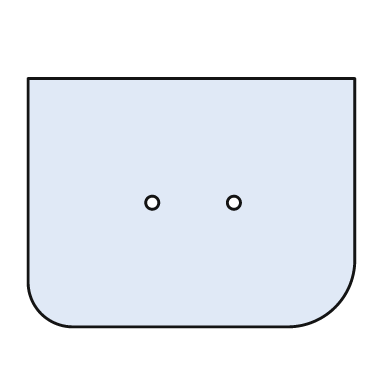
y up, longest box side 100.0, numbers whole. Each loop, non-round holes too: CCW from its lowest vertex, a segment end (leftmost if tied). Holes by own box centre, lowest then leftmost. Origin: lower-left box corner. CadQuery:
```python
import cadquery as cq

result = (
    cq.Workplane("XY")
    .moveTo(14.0, 0.0)
    .lineTo(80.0, 0.0)
    .threePointArc((94.0, 6.0), (100.0, 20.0))
    .lineTo(100.0, 76.0)
    .lineTo(0.0, 76.0)
    .lineTo(0.0, 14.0)
    .threePointArc((4.0, 4.0), (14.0, 0.0))
    .close()
    .moveTo(38.0, 38.0)
    .circle(2.0)
    .moveTo(63.0, 38.0)
    .circle(2.0)
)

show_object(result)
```